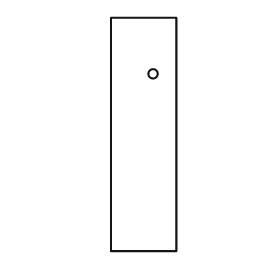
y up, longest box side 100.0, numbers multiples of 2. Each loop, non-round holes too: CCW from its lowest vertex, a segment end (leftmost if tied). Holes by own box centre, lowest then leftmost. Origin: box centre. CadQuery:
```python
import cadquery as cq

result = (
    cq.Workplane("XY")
    .moveTo(-14.0, -50.0)
    .lineTo(14.0, -50.0)
    .lineTo(14.0, 50.0)
    .lineTo(-14.0, 50.0)
    .close()
    .moveTo(4.0, 26.0)
    .circle(2.0)
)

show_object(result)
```